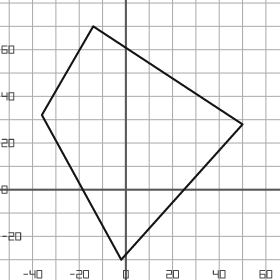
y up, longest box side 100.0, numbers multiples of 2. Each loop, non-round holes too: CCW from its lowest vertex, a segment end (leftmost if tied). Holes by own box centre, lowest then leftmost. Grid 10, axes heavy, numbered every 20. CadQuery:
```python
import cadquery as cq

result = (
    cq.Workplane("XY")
    .moveTo(-2.0, -30.0)
    .lineTo(50.0, 28.0)
    .lineTo(-14.0, 70.0)
    .lineTo(-36.0, 32.0)
    .close()
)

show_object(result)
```